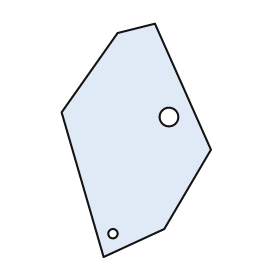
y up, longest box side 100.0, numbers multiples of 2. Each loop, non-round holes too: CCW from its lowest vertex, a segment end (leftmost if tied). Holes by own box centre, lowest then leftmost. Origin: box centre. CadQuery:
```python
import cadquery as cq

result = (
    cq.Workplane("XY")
    .moveTo(-14.0, -50.0)
    .lineTo(12.0, -38.0)
    .lineTo(32.0, -4.0)
    .lineTo(8.0, 50.0)
    .lineTo(-8.0, 46.0)
    .lineTo(-32.0, 12.0)
    .close()
    .moveTo(-10.0, -40.0)
    .circle(2.0)
    .moveTo(14.0, 10.0)
    .circle(4.0)
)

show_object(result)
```